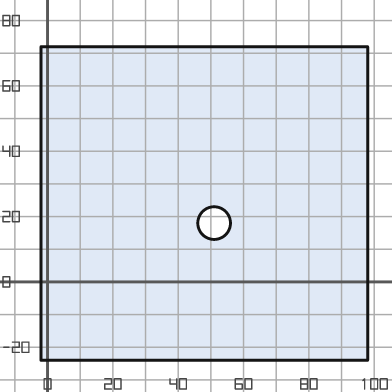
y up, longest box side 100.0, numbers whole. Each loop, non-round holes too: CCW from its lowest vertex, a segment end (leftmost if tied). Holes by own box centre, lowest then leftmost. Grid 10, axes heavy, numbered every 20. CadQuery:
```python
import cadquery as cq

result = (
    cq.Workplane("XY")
    .moveTo(-2.0, -24.0)
    .lineTo(98.0, -24.0)
    .lineTo(98.0, 72.0)
    .lineTo(-2.0, 72.0)
    .close()
    .moveTo(51.0, 18.0)
    .circle(5.0)
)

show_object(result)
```